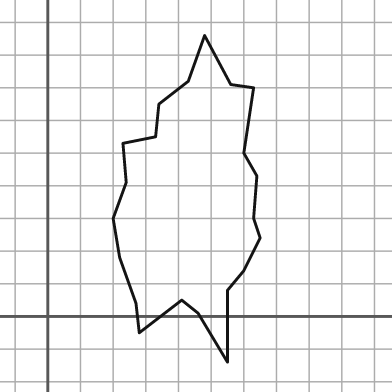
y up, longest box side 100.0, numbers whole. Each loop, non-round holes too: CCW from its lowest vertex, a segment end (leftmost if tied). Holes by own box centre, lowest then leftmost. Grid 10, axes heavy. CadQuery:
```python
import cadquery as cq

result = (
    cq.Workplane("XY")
    .moveTo(55.0, -14.0)
    .lineTo(55.0, 8.0)
    .lineTo(60.0, 14.0)
    .lineTo(65.0, 24.0)
    .lineTo(63.0, 30.0)
    .lineTo(64.0, 43.0)
    .lineTo(60.0, 50.0)
    .lineTo(63.0, 70.0)
    .lineTo(56.0, 71.0)
    .lineTo(48.0, 86.0)
    .lineTo(43.0, 72.0)
    .lineTo(34.0, 65.0)
    .lineTo(33.0, 55.0)
    .lineTo(23.0, 53.0)
    .lineTo(24.0, 41.0)
    .lineTo(20.0, 30.0)
    .lineTo(22.0, 18.0)
    .lineTo(27.0, 4.0)
    .lineTo(28.0, -5.0)
    .lineTo(41.0, 5.0)
    .lineTo(46.0, 1.0)
    .close()
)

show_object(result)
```